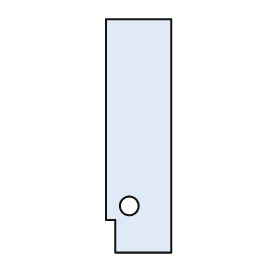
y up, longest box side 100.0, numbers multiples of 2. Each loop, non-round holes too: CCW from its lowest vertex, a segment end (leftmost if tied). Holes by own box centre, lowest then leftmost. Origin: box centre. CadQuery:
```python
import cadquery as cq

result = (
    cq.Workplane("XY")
    .moveTo(-10.0, -50.0)
    .lineTo(14.0, -50.0)
    .lineTo(14.0, 50.0)
    .lineTo(-14.0, 50.0)
    .lineTo(-14.0, -36.0)
    .lineTo(-10.0, -36.0)
    .close()
    .moveTo(-4.0, -30.0)
    .circle(4.0)
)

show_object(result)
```